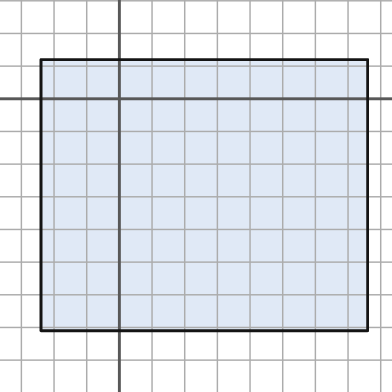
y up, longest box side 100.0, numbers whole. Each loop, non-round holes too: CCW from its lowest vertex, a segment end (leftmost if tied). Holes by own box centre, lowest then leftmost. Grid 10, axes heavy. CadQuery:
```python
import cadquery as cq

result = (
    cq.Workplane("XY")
    .moveTo(-24.0, -71.0)
    .lineTo(76.0, -71.0)
    .lineTo(76.0, 12.0)
    .lineTo(-24.0, 12.0)
    .close()
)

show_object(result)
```